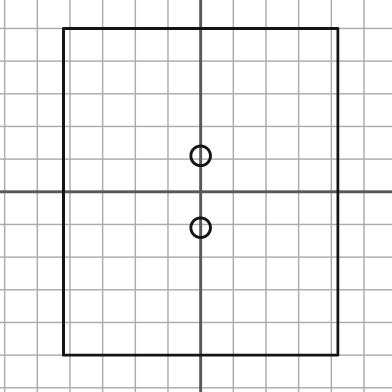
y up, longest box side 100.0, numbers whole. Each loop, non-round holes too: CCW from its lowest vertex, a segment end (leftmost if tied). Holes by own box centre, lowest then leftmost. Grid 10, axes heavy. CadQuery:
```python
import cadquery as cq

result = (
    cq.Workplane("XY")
    .moveTo(-42.0, -50.0)
    .lineTo(42.0, -50.0)
    .lineTo(42.0, 50.0)
    .lineTo(-42.0, 50.0)
    .close()
    .moveTo(0.0, -11.0)
    .circle(3.0)
    .moveTo(0.0, 11.0)
    .circle(3.0)
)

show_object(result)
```